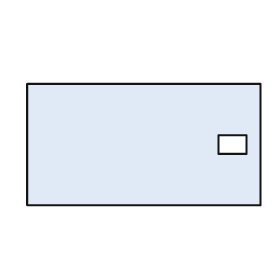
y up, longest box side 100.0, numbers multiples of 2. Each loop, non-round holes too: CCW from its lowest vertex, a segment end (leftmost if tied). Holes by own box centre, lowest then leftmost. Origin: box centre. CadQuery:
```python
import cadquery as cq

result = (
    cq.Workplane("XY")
    .moveTo(-50.0, -26.0)
    .lineTo(50.0, -26.0)
    .lineTo(50.0, 26.0)
    .lineTo(-50.0, 26.0)
    .close()
    .moveTo(32.0, -4.0)
    .lineTo(44.0, -4.0)
    .lineTo(44.0, 4.0)
    .lineTo(32.0, 4.0)
    .close()
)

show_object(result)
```